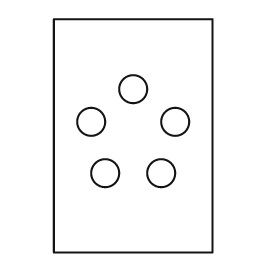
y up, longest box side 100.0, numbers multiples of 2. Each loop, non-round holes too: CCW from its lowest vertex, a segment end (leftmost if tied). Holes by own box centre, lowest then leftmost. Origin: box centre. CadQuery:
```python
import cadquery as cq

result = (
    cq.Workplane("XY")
    .moveTo(-34.0, -50.0)
    .lineTo(34.0, -50.0)
    .lineTo(34.0, 50.0)
    .lineTo(-34.0, 50.0)
    .close()
    .moveTo(-12.0, -16.0)
    .circle(6.0)
    .moveTo(12.0, -16.0)
    .circle(6.0)
    .moveTo(-18.0, 6.0)
    .circle(6.0)
    .moveTo(18.0, 6.0)
    .circle(6.0)
    .moveTo(0.0, 20.0)
    .circle(6.0)
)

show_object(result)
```